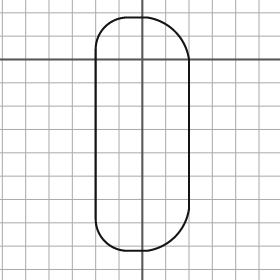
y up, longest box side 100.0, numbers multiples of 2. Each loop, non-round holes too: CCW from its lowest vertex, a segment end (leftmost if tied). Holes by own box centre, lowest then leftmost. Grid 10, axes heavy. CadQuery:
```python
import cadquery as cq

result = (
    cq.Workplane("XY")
    .moveTo(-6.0, -82.0)
    .lineTo(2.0, -82.0)
    .threePointArc((14.0, -76.0), (20.0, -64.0))
    .lineTo(20.0, 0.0)
    .threePointArc((14.0, 12.0), (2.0, 18.0))
    .lineTo(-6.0, 18.0)
    .threePointArc((-16.0, 14.0), (-20.0, 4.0))
    .lineTo(-20.0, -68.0)
    .threePointArc((-16.0, -78.0), (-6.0, -82.0))
    .close()
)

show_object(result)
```